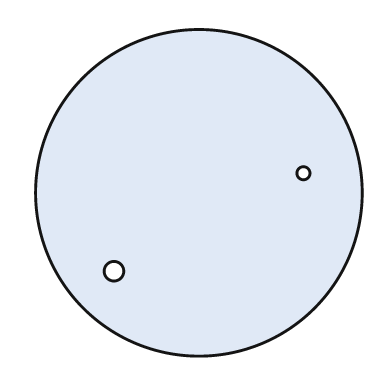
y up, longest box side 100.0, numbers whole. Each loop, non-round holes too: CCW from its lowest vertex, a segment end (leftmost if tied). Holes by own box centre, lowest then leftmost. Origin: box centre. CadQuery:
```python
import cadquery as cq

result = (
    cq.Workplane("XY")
    .moveTo(0.0, 0.0)
    .circle(50.0)
    .moveTo(-26.0, -24.0)
    .circle(3.0)
    .moveTo(32.0, 6.0)
    .circle(2.0)
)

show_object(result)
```